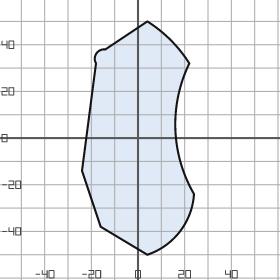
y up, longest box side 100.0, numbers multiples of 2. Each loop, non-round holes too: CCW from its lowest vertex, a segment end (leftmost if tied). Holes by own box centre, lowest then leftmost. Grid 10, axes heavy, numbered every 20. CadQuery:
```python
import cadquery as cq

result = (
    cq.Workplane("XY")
    .moveTo(4.0, -50.0)
    .threePointArc((18.0, -40.0), (24.0, -24.0))
    .threePointArc((16.0, 4.0), (22.0, 32.0))
    .threePointArc((14.0, 42.0), (4.0, 50.0))
    .lineTo(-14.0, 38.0)
    .threePointArc((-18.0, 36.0), (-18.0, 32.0))
    .lineTo(-24.0, -14.0)
    .lineTo(-16.0, -38.0)
    .close()
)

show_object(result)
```